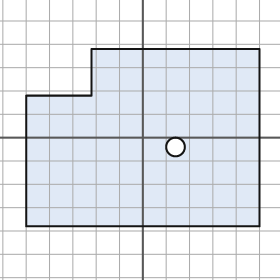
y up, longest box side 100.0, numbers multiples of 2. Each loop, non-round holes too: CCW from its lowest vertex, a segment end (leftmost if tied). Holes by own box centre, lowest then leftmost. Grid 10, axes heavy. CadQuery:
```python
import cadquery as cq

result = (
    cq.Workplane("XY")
    .moveTo(-50.0, -38.0)
    .lineTo(50.0, -38.0)
    .lineTo(50.0, 38.0)
    .lineTo(-22.0, 38.0)
    .lineTo(-22.0, 18.0)
    .lineTo(-50.0, 18.0)
    .close()
    .moveTo(14.0, -4.0)
    .circle(4.0)
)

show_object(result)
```